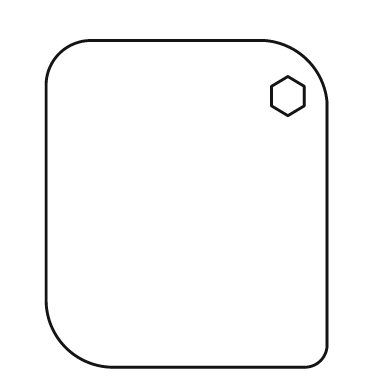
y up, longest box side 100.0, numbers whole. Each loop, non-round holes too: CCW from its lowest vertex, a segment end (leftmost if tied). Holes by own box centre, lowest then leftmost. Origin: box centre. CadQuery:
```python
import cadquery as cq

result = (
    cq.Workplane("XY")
    .moveTo(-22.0, -50.0)
    .lineTo(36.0, -50.0)
    .threePointArc((41.0, -48.0), (43.0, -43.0))
    .lineTo(43.0, 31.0)
    .threePointArc((37.0, 44.0), (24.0, 50.0))
    .lineTo(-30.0, 50.0)
    .threePointArc((-39.0, 46.0), (-43.0, 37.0))
    .lineTo(-43.0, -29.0)
    .threePointArc((-37.0, -44.0), (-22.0, -50.0))
    .close()
    .moveTo(31.0, 27.0)
    .lineTo(36.0, 30.0)
    .lineTo(36.0, 36.0)
    .lineTo(31.0, 39.0)
    .lineTo(26.0, 36.0)
    .lineTo(26.0, 30.0)
    .close()
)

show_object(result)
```